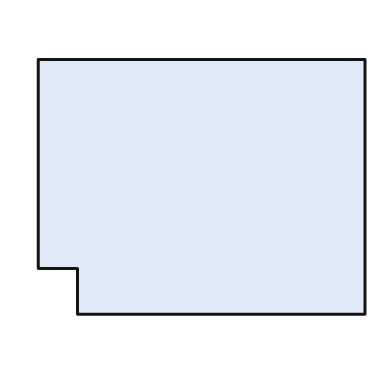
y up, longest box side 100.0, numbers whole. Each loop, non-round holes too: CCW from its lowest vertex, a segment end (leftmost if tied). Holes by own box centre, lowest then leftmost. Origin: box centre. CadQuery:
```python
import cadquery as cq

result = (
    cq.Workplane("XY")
    .moveTo(-38.0, -39.0)
    .lineTo(50.0, -39.0)
    .lineTo(50.0, 39.0)
    .lineTo(-50.0, 39.0)
    .lineTo(-50.0, -25.0)
    .lineTo(-38.0, -25.0)
    .close()
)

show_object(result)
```